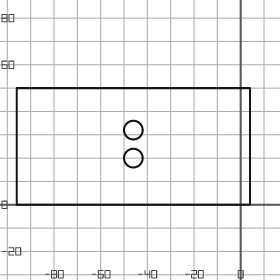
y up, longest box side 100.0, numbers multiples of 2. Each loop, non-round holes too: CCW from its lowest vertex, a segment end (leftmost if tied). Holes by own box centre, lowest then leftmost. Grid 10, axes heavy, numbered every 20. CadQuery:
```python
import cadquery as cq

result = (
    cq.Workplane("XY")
    .moveTo(-96.0, 0.0)
    .lineTo(4.0, 0.0)
    .lineTo(4.0, 50.0)
    .lineTo(-96.0, 50.0)
    .close()
    .moveTo(-46.0, 20.0)
    .circle(4.0)
    .moveTo(-46.0, 32.0)
    .circle(4.0)
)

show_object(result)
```